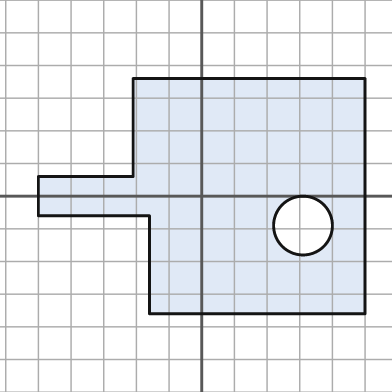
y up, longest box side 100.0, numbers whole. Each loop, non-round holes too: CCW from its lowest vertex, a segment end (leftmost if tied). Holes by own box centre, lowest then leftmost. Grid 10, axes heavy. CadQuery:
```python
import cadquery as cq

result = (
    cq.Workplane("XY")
    .moveTo(-16.0, -36.0)
    .lineTo(50.0, -36.0)
    .lineTo(50.0, 36.0)
    .lineTo(-21.0, 36.0)
    .lineTo(-21.0, 6.0)
    .lineTo(-50.0, 6.0)
    .lineTo(-50.0, -6.0)
    .lineTo(-16.0, -6.0)
    .close()
    .moveTo(31.0, -9.0)
    .circle(9.0)
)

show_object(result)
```